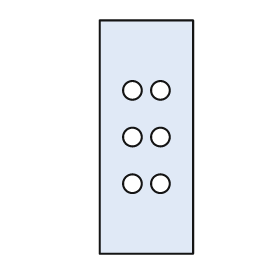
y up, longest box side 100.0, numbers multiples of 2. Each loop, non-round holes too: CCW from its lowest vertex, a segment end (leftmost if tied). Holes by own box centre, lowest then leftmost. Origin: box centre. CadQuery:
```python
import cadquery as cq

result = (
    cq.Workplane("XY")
    .moveTo(-20.0, -50.0)
    .lineTo(20.0, -50.0)
    .lineTo(20.0, 50.0)
    .lineTo(-20.0, 50.0)
    .close()
    .moveTo(-6.0, -20.0)
    .circle(4.0)
    .moveTo(6.0, -20.0)
    .circle(4.0)
    .moveTo(-6.0, 0.0)
    .circle(4.0)
    .moveTo(6.0, 0.0)
    .circle(4.0)
    .moveTo(-6.0, 20.0)
    .circle(4.0)
    .moveTo(6.0, 20.0)
    .circle(4.0)
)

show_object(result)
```